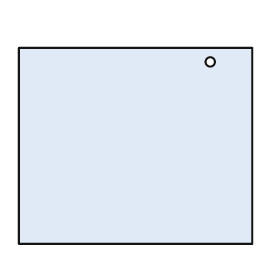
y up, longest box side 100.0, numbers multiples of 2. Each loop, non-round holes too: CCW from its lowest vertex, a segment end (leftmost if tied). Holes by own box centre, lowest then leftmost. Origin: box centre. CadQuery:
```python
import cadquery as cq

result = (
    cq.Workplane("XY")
    .moveTo(-50.0, -42.0)
    .lineTo(50.0, -42.0)
    .lineTo(50.0, 42.0)
    .lineTo(-50.0, 42.0)
    .close()
    .moveTo(32.0, 36.0)
    .circle(2.0)
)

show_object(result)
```